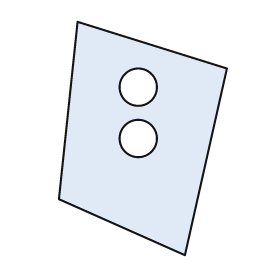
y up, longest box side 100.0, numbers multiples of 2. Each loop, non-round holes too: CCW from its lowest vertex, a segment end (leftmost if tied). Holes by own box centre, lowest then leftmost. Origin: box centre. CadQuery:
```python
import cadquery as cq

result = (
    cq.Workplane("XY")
    .moveTo(18.0, -50.0)
    .lineTo(36.0, 30.0)
    .lineTo(-28.0, 50.0)
    .lineTo(-36.0, -26.0)
    .close()
    .moveTo(-2.0, 0.0)
    .circle(8.0)
    .moveTo(-2.0, 22.0)
    .circle(8.0)
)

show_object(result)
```